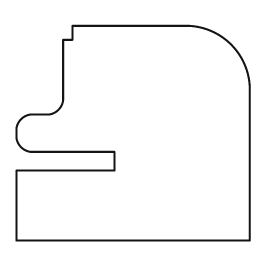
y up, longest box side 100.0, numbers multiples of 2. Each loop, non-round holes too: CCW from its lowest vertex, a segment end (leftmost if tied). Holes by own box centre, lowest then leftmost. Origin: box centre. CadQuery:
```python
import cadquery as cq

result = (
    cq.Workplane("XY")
    .moveTo(-50.0, -46.0)
    .lineTo(50.0, -46.0)
    .lineTo(50.0, 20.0)
    .threePointArc((42.0, 38.0), (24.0, 46.0))
    .lineTo(-26.0, 46.0)
    .lineTo(-26.0, 40.0)
    .lineTo(-30.0, 40.0)
    .lineTo(-30.0, 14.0)
    .threePointArc((-32.0, 10.0), (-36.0, 8.0))
    .lineTo(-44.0, 8.0)
    .threePointArc((-48.0, 6.0), (-50.0, 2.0))
    .lineTo(-50.0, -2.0)
    .threePointArc((-48.0, -6.0), (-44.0, -8.0))
    .lineTo(-8.0, -8.0)
    .lineTo(-8.0, -16.0)
    .lineTo(-50.0, -16.0)
    .close()
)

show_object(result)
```